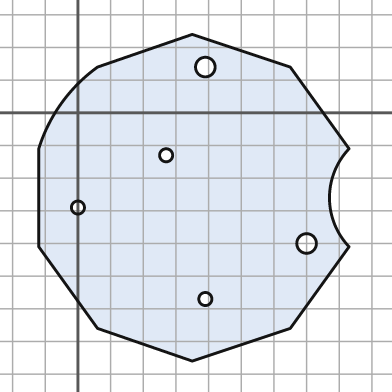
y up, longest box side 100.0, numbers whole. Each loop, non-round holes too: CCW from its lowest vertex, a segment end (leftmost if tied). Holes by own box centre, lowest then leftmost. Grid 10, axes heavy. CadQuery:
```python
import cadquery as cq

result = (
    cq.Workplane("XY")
    .moveTo(35.0, -76.0)
    .lineTo(65.0, -66.0)
    .lineTo(83.0, -41.0)
    .threePointArc((77.0, -26.0), (83.0, -11.0))
    .lineTo(65.0, 14.0)
    .lineTo(35.0, 24.0)
    .lineTo(6.0, 14.0)
    .threePointArc((-5.0, 3.0), (-12.0, -11.0))
    .lineTo(-12.0, -41.0)
    .lineTo(6.0, -66.0)
    .close()
    .moveTo(39.0, -57.0)
    .circle(2.0)
    .moveTo(70.0, -40.0)
    .circle(3.0)
    .moveTo(0.0, -29.0)
    .circle(2.0)
    .moveTo(27.0, -13.0)
    .circle(2.0)
    .moveTo(39.0, 14.0)
    .circle(3.0)
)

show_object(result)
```